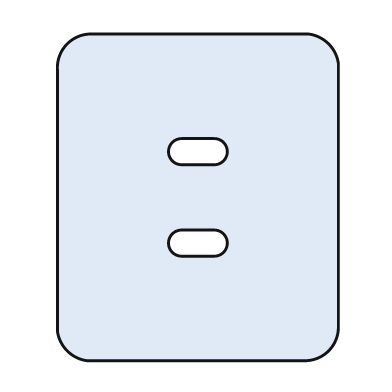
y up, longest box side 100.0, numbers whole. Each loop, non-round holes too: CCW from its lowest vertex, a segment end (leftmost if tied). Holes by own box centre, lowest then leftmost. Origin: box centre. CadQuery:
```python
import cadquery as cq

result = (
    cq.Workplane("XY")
    .moveTo(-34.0, -50.0)
    .lineTo(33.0, -50.0)
    .threePointArc((40.0, -47.0), (43.0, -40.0))
    .lineTo(43.0, 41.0)
    .threePointArc((40.0, 47.0), (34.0, 50.0))
    .lineTo(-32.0, 50.0)
    .threePointArc((-40.0, 47.0), (-43.0, 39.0))
    .lineTo(-43.0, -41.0)
    .threePointArc((-40.0, -47.0), (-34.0, -50.0))
    .close()
    .moveTo(-5.0, -18.0)
    .lineTo(5.0, -18.0)
    .threePointArc((9.0, -14.0), (5.0, -10.0))
    .lineTo(-5.0, -10.0)
    .threePointArc((-9.0, -14.0), (-5.0, -18.0))
    .close()
    .moveTo(-5.0, 10.0)
    .lineTo(5.0, 10.0)
    .threePointArc((9.0, 14.0), (5.0, 18.0))
    .lineTo(-5.0, 18.0)
    .threePointArc((-9.0, 14.0), (-5.0, 10.0))
    .close()
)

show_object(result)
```